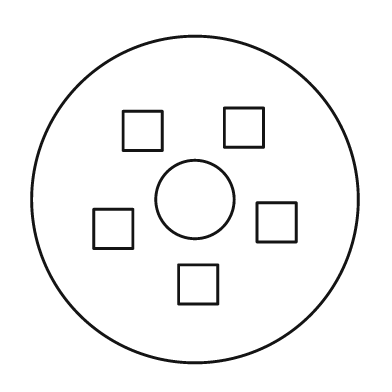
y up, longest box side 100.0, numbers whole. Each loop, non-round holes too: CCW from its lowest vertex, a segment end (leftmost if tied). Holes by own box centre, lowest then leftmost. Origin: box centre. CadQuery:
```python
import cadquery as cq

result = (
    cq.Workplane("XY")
    .moveTo(0.0, 0.0)
    .circle(50.0)
    .moveTo(-5.0, -32.0)
    .lineTo(7.0, -32.0)
    .lineTo(7.0, -20.0)
    .lineTo(-5.0, -20.0)
    .close()
    .moveTo(-31.0, -15.0)
    .lineTo(-19.0, -15.0)
    .lineTo(-19.0, -3.0)
    .lineTo(-31.0, -3.0)
    .close()
    .moveTo(19.0, -13.0)
    .lineTo(31.0, -13.0)
    .lineTo(31.0, -1.0)
    .lineTo(19.0, -1.0)
    .close()
    .moveTo(0.0, 0.0)
    .circle(12.0)
    .moveTo(-22.0, 15.0)
    .lineTo(-10.0, 15.0)
    .lineTo(-10.0, 27.0)
    .lineTo(-22.0, 27.0)
    .close()
    .moveTo(9.0, 16.0)
    .lineTo(21.0, 16.0)
    .lineTo(21.0, 28.0)
    .lineTo(9.0, 28.0)
    .close()
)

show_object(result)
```